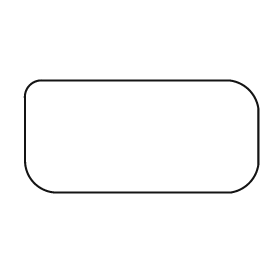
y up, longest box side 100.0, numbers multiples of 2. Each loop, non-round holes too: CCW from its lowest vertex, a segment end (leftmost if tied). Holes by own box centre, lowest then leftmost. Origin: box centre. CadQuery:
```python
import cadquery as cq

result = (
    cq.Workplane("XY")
    .moveTo(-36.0, -24.0)
    .lineTo(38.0, -24.0)
    .threePointArc((46.0, -20.0), (50.0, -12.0))
    .lineTo(50.0, 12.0)
    .threePointArc((46.0, 20.0), (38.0, 24.0))
    .lineTo(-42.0, 24.0)
    .threePointArc((-48.0, 22.0), (-50.0, 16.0))
    .lineTo(-50.0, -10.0)
    .threePointArc((-46.0, -20.0), (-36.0, -24.0))
    .close()
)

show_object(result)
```